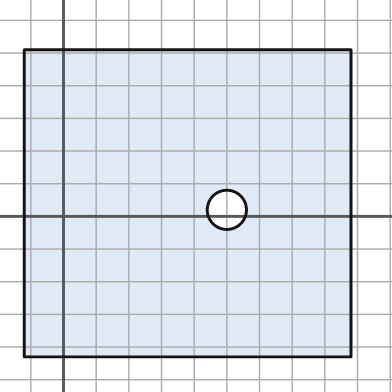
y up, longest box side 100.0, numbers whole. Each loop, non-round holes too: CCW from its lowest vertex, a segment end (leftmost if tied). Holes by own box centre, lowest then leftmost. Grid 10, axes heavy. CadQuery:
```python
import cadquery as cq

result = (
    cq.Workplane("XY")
    .moveTo(-12.0, -43.0)
    .lineTo(88.0, -43.0)
    .lineTo(88.0, 51.0)
    .lineTo(-12.0, 51.0)
    .close()
    .moveTo(50.0, 2.0)
    .circle(6.0)
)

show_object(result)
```